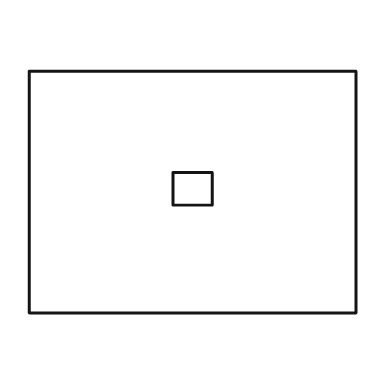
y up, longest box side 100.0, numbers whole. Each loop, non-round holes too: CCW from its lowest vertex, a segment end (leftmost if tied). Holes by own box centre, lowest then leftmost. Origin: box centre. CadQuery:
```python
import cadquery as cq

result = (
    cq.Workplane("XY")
    .moveTo(-50.0, -37.0)
    .lineTo(50.0, -37.0)
    .lineTo(50.0, 37.0)
    .lineTo(-50.0, 37.0)
    .close()
    .moveTo(-6.0, -4.0)
    .lineTo(6.0, -4.0)
    .lineTo(6.0, 6.0)
    .lineTo(-6.0, 6.0)
    .close()
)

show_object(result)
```